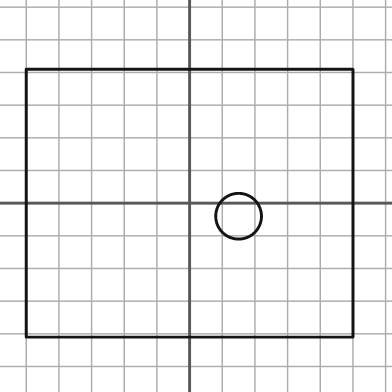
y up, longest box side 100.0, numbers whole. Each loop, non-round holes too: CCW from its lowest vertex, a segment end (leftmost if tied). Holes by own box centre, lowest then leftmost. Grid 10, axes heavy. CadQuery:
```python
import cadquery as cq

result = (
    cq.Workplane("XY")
    .moveTo(-50.0, -41.0)
    .lineTo(50.0, -41.0)
    .lineTo(50.0, 41.0)
    .lineTo(-50.0, 41.0)
    .close()
    .moveTo(15.0, -4.0)
    .circle(7.0)
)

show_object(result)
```